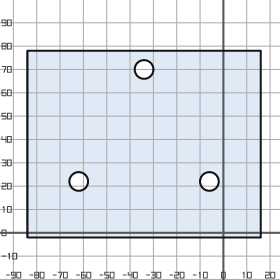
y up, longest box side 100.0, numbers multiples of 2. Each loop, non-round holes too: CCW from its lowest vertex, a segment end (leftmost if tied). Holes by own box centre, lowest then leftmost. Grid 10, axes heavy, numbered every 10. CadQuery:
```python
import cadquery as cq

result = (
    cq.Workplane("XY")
    .moveTo(-84.0, -2.0)
    .lineTo(16.0, -2.0)
    .lineTo(16.0, 78.0)
    .lineTo(-84.0, 78.0)
    .close()
    .moveTo(-62.0, 22.0)
    .circle(4.0)
    .moveTo(-6.0, 22.0)
    .circle(4.0)
    .moveTo(-34.0, 70.0)
    .circle(4.0)
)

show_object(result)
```